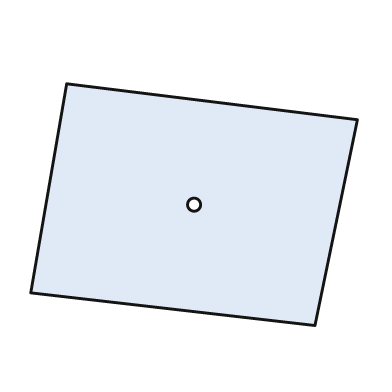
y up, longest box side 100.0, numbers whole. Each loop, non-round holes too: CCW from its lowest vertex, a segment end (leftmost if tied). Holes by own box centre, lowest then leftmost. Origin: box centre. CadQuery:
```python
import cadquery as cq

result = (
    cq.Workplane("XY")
    .moveTo(37.0, -37.0)
    .lineTo(50.0, 26.0)
    .lineTo(-39.0, 37.0)
    .lineTo(-50.0, -27.0)
    .close()
    .moveTo(0.0, 0.0)
    .circle(2.0)
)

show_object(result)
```